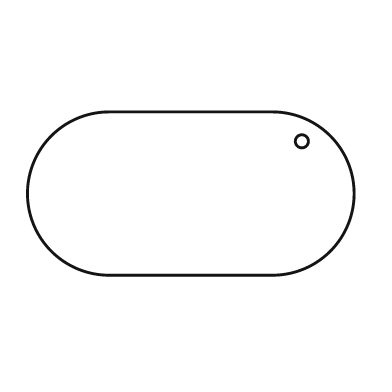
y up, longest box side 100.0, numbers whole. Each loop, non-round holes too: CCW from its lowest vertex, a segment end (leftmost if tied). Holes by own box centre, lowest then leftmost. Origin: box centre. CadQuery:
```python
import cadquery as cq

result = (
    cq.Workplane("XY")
    .moveTo(-25.0, -25.0)
    .lineTo(25.0, -25.0)
    .threePointArc((50.0, 0.0), (25.0, 25.0))
    .lineTo(-25.0, 25.0)
    .threePointArc((-50.0, 0.0), (-25.0, -25.0))
    .close()
    .moveTo(34.0, 16.0)
    .circle(2.0)
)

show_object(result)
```